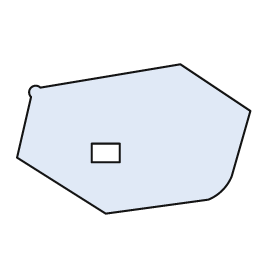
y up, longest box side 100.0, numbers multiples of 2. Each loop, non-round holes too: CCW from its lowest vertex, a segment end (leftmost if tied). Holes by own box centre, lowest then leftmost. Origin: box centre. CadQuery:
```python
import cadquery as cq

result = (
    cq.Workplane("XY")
    .moveTo(-12.0, -32.0)
    .lineTo(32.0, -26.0)
    .threePointArc((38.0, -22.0), (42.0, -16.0))
    .lineTo(50.0, 12.0)
    .lineTo(20.0, 32.0)
    .lineTo(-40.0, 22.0)
    .threePointArc((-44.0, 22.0), (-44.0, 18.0))
    .lineTo(-50.0, -8.0)
    .close()
    .moveTo(-18.0, -10.0)
    .lineTo(-6.0, -10.0)
    .lineTo(-6.0, -2.0)
    .lineTo(-18.0, -2.0)
    .close()
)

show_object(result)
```